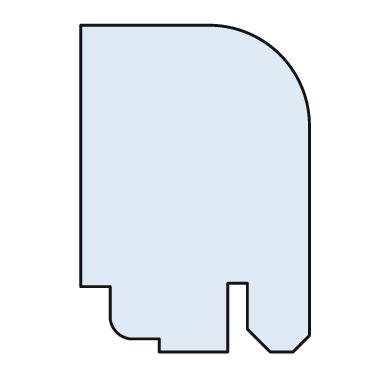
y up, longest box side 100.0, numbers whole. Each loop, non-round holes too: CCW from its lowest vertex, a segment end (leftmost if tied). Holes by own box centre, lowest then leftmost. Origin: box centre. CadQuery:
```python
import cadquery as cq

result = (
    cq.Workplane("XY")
    .moveTo(-11.0, -50.0)
    .lineTo(10.0, -50.0)
    .lineTo(10.0, -29.0)
    .lineTo(16.0, -29.0)
    .lineTo(16.0, -43.0)
    .lineTo(23.0, -50.0)
    .lineTo(30.0, -50.0)
    .lineTo(35.0, -45.0)
    .lineTo(35.0, 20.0)
    .threePointArc((26.0, 41.0), (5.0, 50.0))
    .lineTo(-35.0, 50.0)
    .lineTo(-35.0, -30.0)
    .lineTo(-26.0, -30.0)
    .lineTo(-26.0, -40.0)
    .threePointArc((-24.0, -44.0), (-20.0, -46.0))
    .lineTo(-11.0, -46.0)
    .close()
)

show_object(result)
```